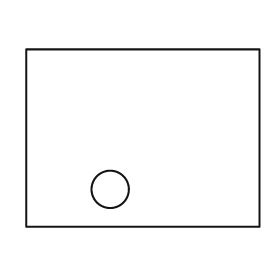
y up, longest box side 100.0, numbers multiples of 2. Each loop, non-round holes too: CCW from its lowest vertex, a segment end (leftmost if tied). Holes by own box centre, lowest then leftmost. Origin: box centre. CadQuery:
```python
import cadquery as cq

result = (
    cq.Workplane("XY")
    .moveTo(-50.0, -38.0)
    .lineTo(50.0, -38.0)
    .lineTo(50.0, 38.0)
    .lineTo(-50.0, 38.0)
    .close()
    .moveTo(-14.0, -22.0)
    .circle(8.0)
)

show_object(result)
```